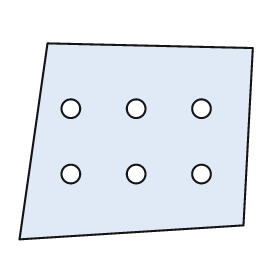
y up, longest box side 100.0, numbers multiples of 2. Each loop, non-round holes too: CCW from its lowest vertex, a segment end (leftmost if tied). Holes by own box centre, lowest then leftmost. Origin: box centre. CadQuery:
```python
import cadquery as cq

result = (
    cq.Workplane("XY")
    .moveTo(-50.0, -42.0)
    .lineTo(46.0, -36.0)
    .lineTo(50.0, 40.0)
    .lineTo(-38.0, 42.0)
    .close()
    .moveTo(-28.0, -14.0)
    .circle(4.0)
    .moveTo(0.0, -14.0)
    .circle(4.0)
    .moveTo(28.0, -14.0)
    .circle(4.0)
    .moveTo(-28.0, 14.0)
    .circle(4.0)
    .moveTo(0.0, 14.0)
    .circle(4.0)
    .moveTo(28.0, 14.0)
    .circle(4.0)
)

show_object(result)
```